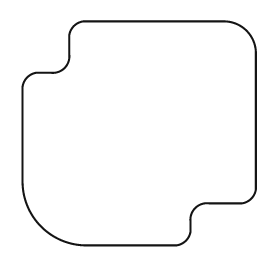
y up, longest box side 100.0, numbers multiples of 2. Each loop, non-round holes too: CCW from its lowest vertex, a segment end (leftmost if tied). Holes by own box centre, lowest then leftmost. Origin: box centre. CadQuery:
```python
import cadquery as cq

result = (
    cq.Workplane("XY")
    .moveTo(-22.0, -48.0)
    .lineTo(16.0, -48.0)
    .threePointArc((20.0, -46.0), (22.0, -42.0))
    .lineTo(22.0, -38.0)
    .threePointArc((24.0, -32.0), (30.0, -30.0))
    .lineTo(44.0, -30.0)
    .threePointArc((48.0, -28.0), (50.0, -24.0))
    .lineTo(50.0, 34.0)
    .threePointArc((46.0, 44.0), (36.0, 48.0))
    .lineTo(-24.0, 48.0)
    .threePointArc((-28.0, 46.0), (-30.0, 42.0))
    .lineTo(-30.0, 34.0)
    .threePointArc((-32.0, 28.0), (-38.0, 26.0))
    .lineTo(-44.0, 26.0)
    .threePointArc((-48.0, 24.0), (-50.0, 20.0))
    .lineTo(-50.0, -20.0)
    .threePointArc((-42.0, -40.0), (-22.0, -48.0))
    .close()
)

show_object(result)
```